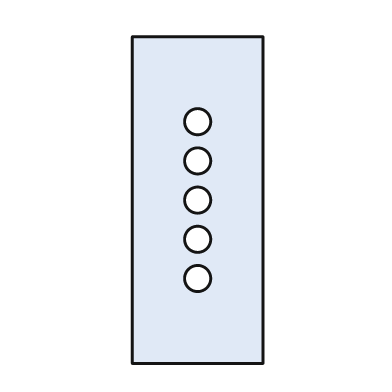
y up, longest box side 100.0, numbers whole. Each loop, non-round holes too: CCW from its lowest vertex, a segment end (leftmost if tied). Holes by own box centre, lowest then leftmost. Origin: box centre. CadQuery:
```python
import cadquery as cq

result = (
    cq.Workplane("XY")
    .moveTo(-20.0, -50.0)
    .lineTo(20.0, -50.0)
    .lineTo(20.0, 50.0)
    .lineTo(-20.0, 50.0)
    .close()
    .moveTo(0.0, -24.0)
    .circle(4.0)
    .moveTo(0.0, -12.0)
    .circle(4.0)
    .moveTo(0.0, 0.0)
    .circle(4.0)
    .moveTo(0.0, 12.0)
    .circle(4.0)
    .moveTo(0.0, 24.0)
    .circle(4.0)
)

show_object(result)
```